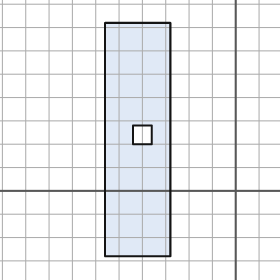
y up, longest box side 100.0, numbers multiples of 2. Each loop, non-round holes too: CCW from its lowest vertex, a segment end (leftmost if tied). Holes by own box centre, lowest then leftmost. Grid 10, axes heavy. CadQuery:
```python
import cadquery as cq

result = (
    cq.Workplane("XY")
    .moveTo(-56.0, -28.0)
    .lineTo(-28.0, -28.0)
    .lineTo(-28.0, 72.0)
    .lineTo(-56.0, 72.0)
    .close()
    .moveTo(-44.0, 20.0)
    .lineTo(-36.0, 20.0)
    .lineTo(-36.0, 28.0)
    .lineTo(-44.0, 28.0)
    .close()
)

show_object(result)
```